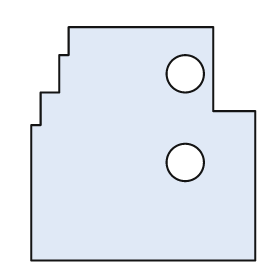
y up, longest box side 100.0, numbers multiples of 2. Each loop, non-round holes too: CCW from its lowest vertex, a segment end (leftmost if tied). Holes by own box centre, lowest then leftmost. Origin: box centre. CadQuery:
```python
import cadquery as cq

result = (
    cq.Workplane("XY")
    .moveTo(-48.0, -50.0)
    .lineTo(48.0, -50.0)
    .lineTo(48.0, 14.0)
    .lineTo(30.0, 14.0)
    .lineTo(30.0, 50.0)
    .lineTo(-32.0, 50.0)
    .lineTo(-32.0, 38.0)
    .lineTo(-36.0, 38.0)
    .lineTo(-36.0, 22.0)
    .lineTo(-44.0, 22.0)
    .lineTo(-44.0, 8.0)
    .lineTo(-48.0, 8.0)
    .close()
    .moveTo(18.0, -8.0)
    .circle(8.0)
    .moveTo(18.0, 30.0)
    .circle(8.0)
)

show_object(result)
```